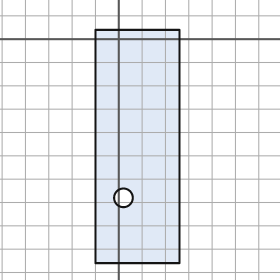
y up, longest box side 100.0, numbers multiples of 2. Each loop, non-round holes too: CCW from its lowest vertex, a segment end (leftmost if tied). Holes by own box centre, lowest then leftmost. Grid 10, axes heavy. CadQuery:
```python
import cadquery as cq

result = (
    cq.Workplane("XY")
    .moveTo(-10.0, -96.0)
    .lineTo(26.0, -96.0)
    .lineTo(26.0, 4.0)
    .lineTo(-10.0, 4.0)
    .close()
    .moveTo(2.0, -68.0)
    .circle(4.0)
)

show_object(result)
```